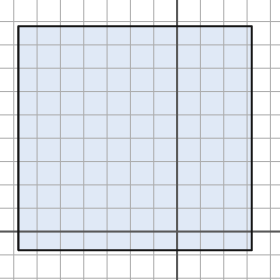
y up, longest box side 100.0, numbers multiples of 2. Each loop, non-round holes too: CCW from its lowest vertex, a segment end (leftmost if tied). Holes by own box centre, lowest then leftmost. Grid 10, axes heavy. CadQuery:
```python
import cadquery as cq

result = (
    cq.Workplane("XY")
    .moveTo(-68.0, -8.0)
    .lineTo(32.0, -8.0)
    .lineTo(32.0, 88.0)
    .lineTo(-68.0, 88.0)
    .close()
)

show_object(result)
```